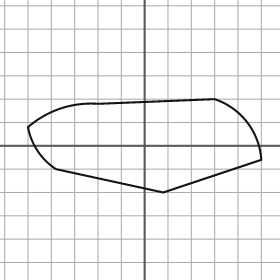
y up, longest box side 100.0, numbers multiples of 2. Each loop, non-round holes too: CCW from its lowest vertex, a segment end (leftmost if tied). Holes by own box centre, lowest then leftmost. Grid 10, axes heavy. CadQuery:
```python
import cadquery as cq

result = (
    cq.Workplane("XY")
    .moveTo(8.0, -20.0)
    .lineTo(50.0, -6.0)
    .threePointArc((44.0, 10.0), (30.0, 20.0))
    .lineTo(-20.0, 18.0)
    .threePointArc((-36.0, 16.0), (-50.0, 8.0))
    .threePointArc((-46.0, -2.0), (-38.0, -10.0))
    .close()
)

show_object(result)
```